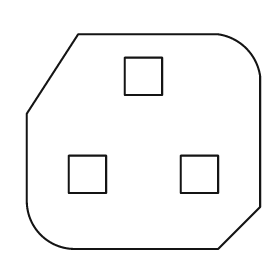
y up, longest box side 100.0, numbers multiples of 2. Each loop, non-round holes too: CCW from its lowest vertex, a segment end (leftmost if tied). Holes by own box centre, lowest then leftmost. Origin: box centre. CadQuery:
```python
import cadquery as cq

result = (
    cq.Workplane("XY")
    .moveTo(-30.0, -46.0)
    .lineTo(32.0, -46.0)
    .lineTo(50.0, -28.0)
    .lineTo(50.0, 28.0)
    .threePointArc((44.0, 40.0), (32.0, 46.0))
    .lineTo(-28.0, 46.0)
    .lineTo(-50.0, 12.0)
    .lineTo(-50.0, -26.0)
    .threePointArc((-44.0, -40.0), (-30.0, -46.0))
    .close()
    .moveTo(-32.0, -22.0)
    .lineTo(-16.0, -22.0)
    .lineTo(-16.0, -6.0)
    .lineTo(-32.0, -6.0)
    .close()
    .moveTo(16.0, -22.0)
    .lineTo(32.0, -22.0)
    .lineTo(32.0, -6.0)
    .lineTo(16.0, -6.0)
    .close()
    .moveTo(-8.0, 20.0)
    .lineTo(8.0, 20.0)
    .lineTo(8.0, 36.0)
    .lineTo(-8.0, 36.0)
    .close()
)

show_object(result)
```